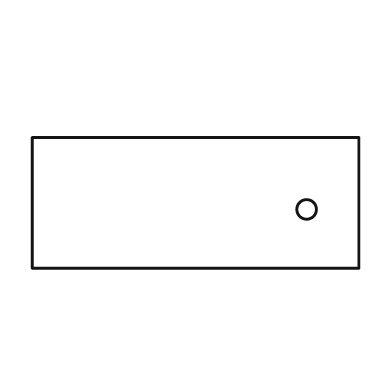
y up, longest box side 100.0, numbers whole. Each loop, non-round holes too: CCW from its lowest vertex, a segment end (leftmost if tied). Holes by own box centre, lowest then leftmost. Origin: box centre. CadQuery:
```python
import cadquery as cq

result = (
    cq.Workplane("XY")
    .moveTo(-50.0, -20.0)
    .lineTo(50.0, -20.0)
    .lineTo(50.0, 20.0)
    .lineTo(-50.0, 20.0)
    .close()
    .moveTo(34.0, -2.0)
    .circle(3.0)
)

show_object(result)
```